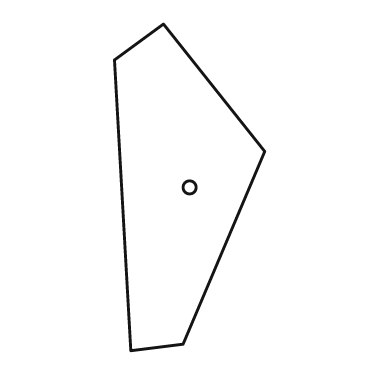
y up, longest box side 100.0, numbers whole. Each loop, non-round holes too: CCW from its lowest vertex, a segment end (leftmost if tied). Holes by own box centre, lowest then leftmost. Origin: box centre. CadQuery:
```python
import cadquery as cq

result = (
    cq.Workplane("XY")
    .moveTo(-18.0, -50.0)
    .lineTo(-2.0, -48.0)
    .lineTo(23.0, 11.0)
    .lineTo(-8.0, 50.0)
    .lineTo(-23.0, 39.0)
    .close()
    .moveTo(0.0, 0.0)
    .circle(2.0)
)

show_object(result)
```